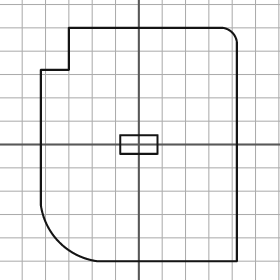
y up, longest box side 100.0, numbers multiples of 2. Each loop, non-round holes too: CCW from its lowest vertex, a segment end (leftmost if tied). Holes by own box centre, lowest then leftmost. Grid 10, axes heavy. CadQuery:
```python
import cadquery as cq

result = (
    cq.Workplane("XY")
    .moveTo(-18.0, -50.0)
    .lineTo(42.0, -50.0)
    .lineTo(42.0, 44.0)
    .threePointArc((40.0, 48.0), (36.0, 50.0))
    .lineTo(-30.0, 50.0)
    .lineTo(-30.0, 32.0)
    .lineTo(-42.0, 32.0)
    .lineTo(-42.0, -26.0)
    .threePointArc((-34.0, -42.0), (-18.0, -50.0))
    .close()
    .moveTo(-8.0, -4.0)
    .lineTo(8.0, -4.0)
    .lineTo(8.0, 4.0)
    .lineTo(-8.0, 4.0)
    .close()
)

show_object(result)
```